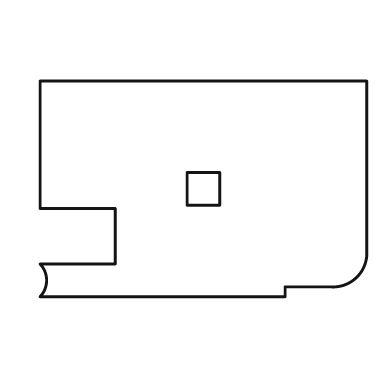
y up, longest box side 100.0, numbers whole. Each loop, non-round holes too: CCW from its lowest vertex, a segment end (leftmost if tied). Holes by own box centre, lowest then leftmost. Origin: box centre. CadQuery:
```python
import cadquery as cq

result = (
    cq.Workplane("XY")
    .moveTo(-50.0, -33.0)
    .lineTo(25.0, -33.0)
    .lineTo(25.0, -30.0)
    .lineTo(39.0, -30.0)
    .threePointArc((47.0, -27.0), (50.0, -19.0))
    .lineTo(50.0, 33.0)
    .lineTo(-50.0, 33.0)
    .lineTo(-50.0, -6.0)
    .lineTo(-27.0, -6.0)
    .lineTo(-27.0, -23.0)
    .lineTo(-50.0, -23.0)
    .threePointArc((-48.0, -28.0), (-50.0, -33.0))
    .close()
    .moveTo(-5.0, -5.0)
    .lineTo(5.0, -5.0)
    .lineTo(5.0, 5.0)
    .lineTo(-5.0, 5.0)
    .close()
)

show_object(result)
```